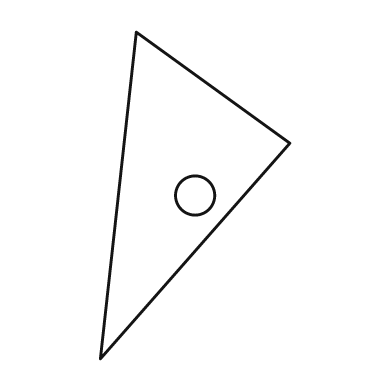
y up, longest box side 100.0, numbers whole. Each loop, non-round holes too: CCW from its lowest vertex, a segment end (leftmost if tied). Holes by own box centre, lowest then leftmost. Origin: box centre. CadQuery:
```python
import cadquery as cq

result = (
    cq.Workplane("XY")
    .moveTo(-29.0, -50.0)
    .lineTo(29.0, 16.0)
    .lineTo(-18.0, 50.0)
    .close()
    .moveTo(0.0, 0.0)
    .circle(6.0)
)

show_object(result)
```